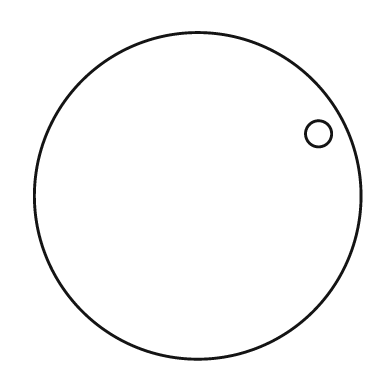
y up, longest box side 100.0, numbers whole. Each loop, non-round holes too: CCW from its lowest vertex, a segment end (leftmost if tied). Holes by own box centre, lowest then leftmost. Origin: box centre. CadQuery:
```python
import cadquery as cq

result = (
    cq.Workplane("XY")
    .moveTo(0.0, 0.0)
    .circle(50.0)
    .moveTo(37.0, 19.0)
    .circle(4.0)
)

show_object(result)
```